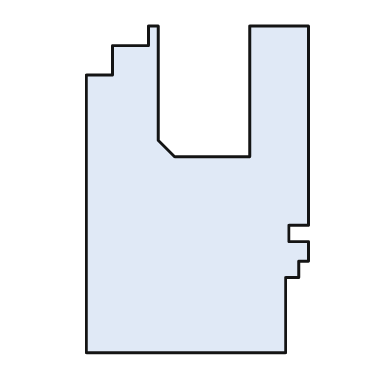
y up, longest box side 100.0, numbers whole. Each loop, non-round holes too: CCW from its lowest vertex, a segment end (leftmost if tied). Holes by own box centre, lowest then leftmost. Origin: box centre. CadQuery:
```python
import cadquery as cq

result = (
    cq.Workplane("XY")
    .moveTo(-34.0, -50.0)
    .lineTo(27.0, -50.0)
    .lineTo(27.0, -27.0)
    .lineTo(31.0, -27.0)
    .lineTo(31.0, -22.0)
    .lineTo(34.0, -22.0)
    .lineTo(34.0, -16.0)
    .lineTo(28.0, -16.0)
    .lineTo(28.0, -11.0)
    .lineTo(34.0, -11.0)
    .lineTo(34.0, 50.0)
    .lineTo(16.0, 50.0)
    .lineTo(16.0, 10.0)
    .lineTo(-7.0, 10.0)
    .lineTo(-12.0, 15.0)
    .lineTo(-12.0, 50.0)
    .lineTo(-15.0, 50.0)
    .lineTo(-15.0, 44.0)
    .lineTo(-26.0, 44.0)
    .lineTo(-26.0, 35.0)
    .lineTo(-34.0, 35.0)
    .close()
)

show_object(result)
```